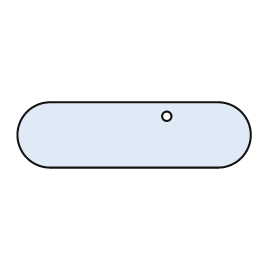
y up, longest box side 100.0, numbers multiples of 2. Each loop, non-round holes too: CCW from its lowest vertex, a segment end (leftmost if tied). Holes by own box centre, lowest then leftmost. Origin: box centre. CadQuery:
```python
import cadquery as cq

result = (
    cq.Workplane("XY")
    .moveTo(-36.0, -14.0)
    .lineTo(36.0, -14.0)
    .threePointArc((50.0, 0.0), (36.0, 14.0))
    .lineTo(-36.0, 14.0)
    .threePointArc((-50.0, 0.0), (-36.0, -14.0))
    .close()
    .moveTo(14.0, 8.0)
    .circle(2.0)
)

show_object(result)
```